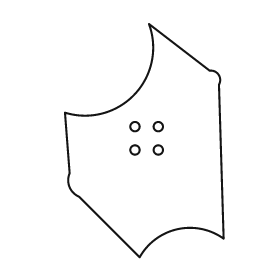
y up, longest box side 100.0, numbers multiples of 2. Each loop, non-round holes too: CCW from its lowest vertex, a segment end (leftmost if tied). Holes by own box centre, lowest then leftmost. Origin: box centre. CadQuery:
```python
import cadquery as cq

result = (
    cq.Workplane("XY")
    .moveTo(-2.0, -50.0)
    .threePointArc((14.0, -38.0), (34.0, -42.0))
    .lineTo(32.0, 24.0)
    .threePointArc((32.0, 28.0), (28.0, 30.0))
    .lineTo(2.0, 50.0)
    .threePointArc((-4.0, 20.0), (-34.0, 12.0))
    .lineTo(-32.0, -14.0)
    .threePointArc((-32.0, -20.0), (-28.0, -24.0))
    .close()
    .moveTo(-4.0, -4.0)
    .circle(2.0)
    .moveTo(6.0, -4.0)
    .circle(2.0)
    .moveTo(-4.0, 6.0)
    .circle(2.0)
    .moveTo(6.0, 6.0)
    .circle(2.0)
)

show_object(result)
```